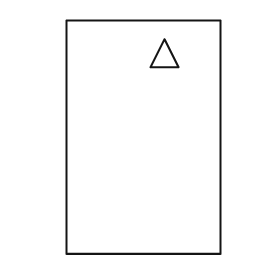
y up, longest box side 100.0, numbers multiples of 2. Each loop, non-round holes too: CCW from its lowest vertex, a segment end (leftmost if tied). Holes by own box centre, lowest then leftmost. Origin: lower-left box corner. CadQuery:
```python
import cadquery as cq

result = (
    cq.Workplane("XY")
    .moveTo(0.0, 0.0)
    .lineTo(66.0, 0.0)
    .lineTo(66.0, 100.0)
    .lineTo(0.0, 100.0)
    .close()
    .moveTo(36.0, 80.0)
    .lineTo(48.0, 80.0)
    .lineTo(42.0, 92.0)
    .close()
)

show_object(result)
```